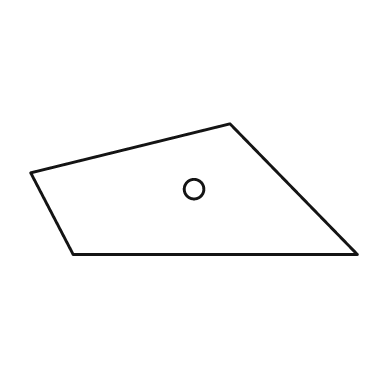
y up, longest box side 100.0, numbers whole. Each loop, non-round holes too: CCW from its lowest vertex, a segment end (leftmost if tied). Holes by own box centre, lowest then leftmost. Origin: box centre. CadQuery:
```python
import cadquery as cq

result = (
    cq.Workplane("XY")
    .moveTo(-37.0, -20.0)
    .lineTo(50.0, -20.0)
    .lineTo(11.0, 20.0)
    .lineTo(-50.0, 5.0)
    .close()
    .moveTo(0.0, 0.0)
    .circle(3.0)
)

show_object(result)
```